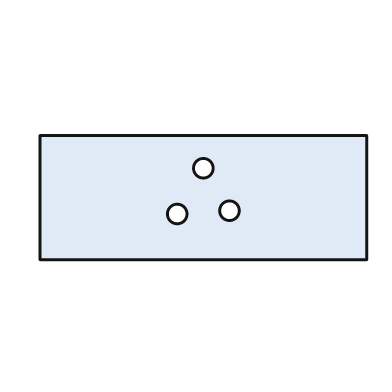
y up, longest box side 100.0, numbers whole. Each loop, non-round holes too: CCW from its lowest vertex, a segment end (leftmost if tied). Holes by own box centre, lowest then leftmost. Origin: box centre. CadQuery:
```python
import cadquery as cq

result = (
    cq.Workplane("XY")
    .moveTo(-50.0, -19.0)
    .lineTo(50.0, -19.0)
    .lineTo(50.0, 19.0)
    .lineTo(-50.0, 19.0)
    .close()
    .moveTo(-8.0, -5.0)
    .circle(3.0)
    .moveTo(8.0, -4.0)
    .circle(3.0)
    .moveTo(0.0, 9.0)
    .circle(3.0)
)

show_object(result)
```